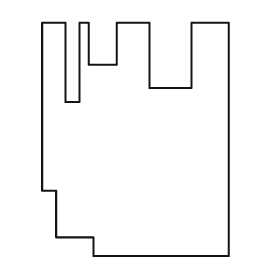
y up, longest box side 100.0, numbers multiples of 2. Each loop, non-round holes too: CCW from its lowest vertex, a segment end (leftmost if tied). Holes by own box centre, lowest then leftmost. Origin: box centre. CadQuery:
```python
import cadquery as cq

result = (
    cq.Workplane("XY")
    .moveTo(-18.0, -50.0)
    .lineTo(40.0, -50.0)
    .lineTo(40.0, 50.0)
    .lineTo(24.0, 50.0)
    .lineTo(24.0, 22.0)
    .lineTo(6.0, 22.0)
    .lineTo(6.0, 50.0)
    .lineTo(-8.0, 50.0)
    .lineTo(-8.0, 32.0)
    .lineTo(-20.0, 32.0)
    .lineTo(-20.0, 50.0)
    .lineTo(-24.0, 50.0)
    .lineTo(-24.0, 16.0)
    .lineTo(-30.0, 16.0)
    .lineTo(-30.0, 50.0)
    .lineTo(-40.0, 50.0)
    .lineTo(-40.0, -22.0)
    .lineTo(-34.0, -22.0)
    .lineTo(-34.0, -42.0)
    .lineTo(-18.0, -42.0)
    .close()
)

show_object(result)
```